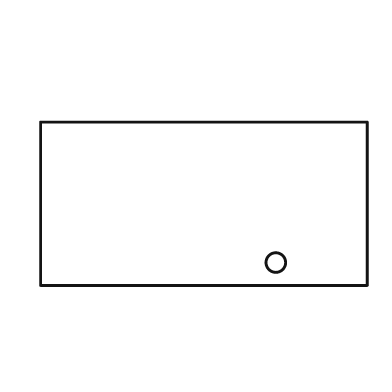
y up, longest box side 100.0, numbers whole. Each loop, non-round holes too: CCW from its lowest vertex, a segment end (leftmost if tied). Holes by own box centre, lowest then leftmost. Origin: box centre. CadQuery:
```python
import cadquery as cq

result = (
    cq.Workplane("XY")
    .moveTo(-50.0, -25.0)
    .lineTo(50.0, -25.0)
    .lineTo(50.0, 25.0)
    .lineTo(-50.0, 25.0)
    .close()
    .moveTo(22.0, -18.0)
    .circle(3.0)
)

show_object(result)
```